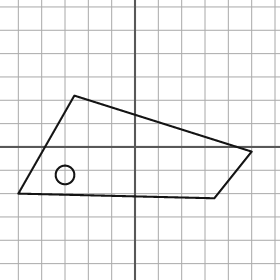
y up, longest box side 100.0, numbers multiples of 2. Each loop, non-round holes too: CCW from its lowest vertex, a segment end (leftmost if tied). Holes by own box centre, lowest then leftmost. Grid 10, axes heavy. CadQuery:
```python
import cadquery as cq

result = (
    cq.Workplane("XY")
    .moveTo(34.0, -22.0)
    .lineTo(50.0, -2.0)
    .lineTo(-26.0, 22.0)
    .lineTo(-50.0, -20.0)
    .close()
    .moveTo(-30.0, -12.0)
    .circle(4.0)
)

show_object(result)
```